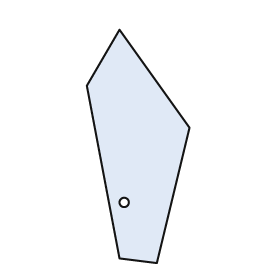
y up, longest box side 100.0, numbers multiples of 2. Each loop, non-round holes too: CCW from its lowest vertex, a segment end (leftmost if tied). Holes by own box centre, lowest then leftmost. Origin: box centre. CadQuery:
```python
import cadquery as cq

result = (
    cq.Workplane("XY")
    .moveTo(8.0, -50.0)
    .lineTo(22.0, 8.0)
    .lineTo(-8.0, 50.0)
    .lineTo(-22.0, 26.0)
    .lineTo(-8.0, -48.0)
    .close()
    .moveTo(-6.0, -24.0)
    .circle(2.0)
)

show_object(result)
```